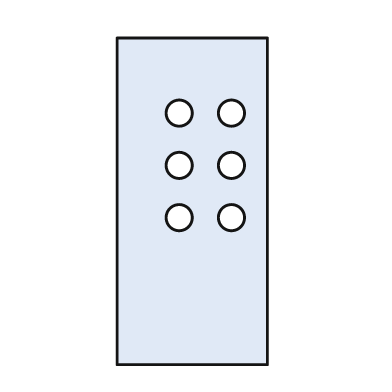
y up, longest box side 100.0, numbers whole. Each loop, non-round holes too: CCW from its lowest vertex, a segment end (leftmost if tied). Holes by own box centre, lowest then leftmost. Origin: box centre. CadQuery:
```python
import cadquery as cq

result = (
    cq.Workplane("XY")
    .moveTo(-23.0, -50.0)
    .lineTo(23.0, -50.0)
    .lineTo(23.0, 50.0)
    .lineTo(-23.0, 50.0)
    .close()
    .moveTo(-4.0, -5.0)
    .circle(4.0)
    .moveTo(12.0, -5.0)
    .circle(4.0)
    .moveTo(-4.0, 11.0)
    .circle(4.0)
    .moveTo(12.0, 11.0)
    .circle(4.0)
    .moveTo(-4.0, 27.0)
    .circle(4.0)
    .moveTo(12.0, 27.0)
    .circle(4.0)
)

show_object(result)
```